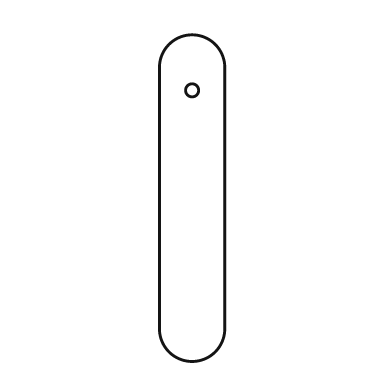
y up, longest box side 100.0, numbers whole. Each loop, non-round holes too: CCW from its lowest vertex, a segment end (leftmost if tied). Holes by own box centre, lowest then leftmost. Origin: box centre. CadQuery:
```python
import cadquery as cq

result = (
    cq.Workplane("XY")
    .moveTo(-10.0, -40.0)
    .threePointArc((0.0, -50.0), (10.0, -40.0))
    .lineTo(10.0, 40.0)
    .threePointArc((0.0, 50.0), (-10.0, 40.0))
    .close()
    .moveTo(0.0, 33.0)
    .circle(2.0)
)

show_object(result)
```